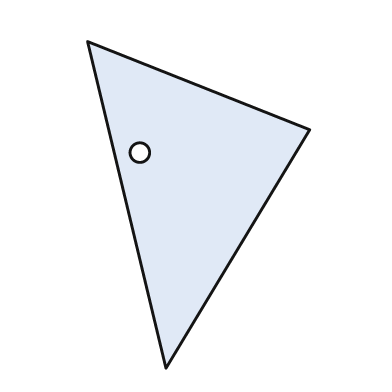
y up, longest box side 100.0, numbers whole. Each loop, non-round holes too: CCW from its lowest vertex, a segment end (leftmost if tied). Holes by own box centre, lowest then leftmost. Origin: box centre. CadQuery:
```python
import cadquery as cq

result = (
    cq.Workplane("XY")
    .moveTo(-10.0, -50.0)
    .lineTo(34.0, 23.0)
    .lineTo(-34.0, 50.0)
    .close()
    .moveTo(-18.0, 16.0)
    .circle(3.0)
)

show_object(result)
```